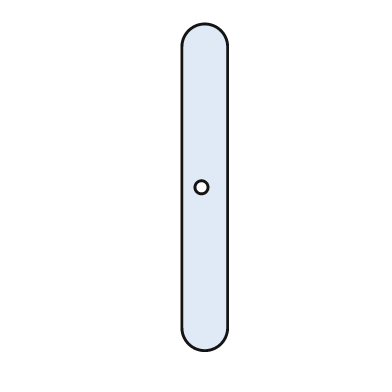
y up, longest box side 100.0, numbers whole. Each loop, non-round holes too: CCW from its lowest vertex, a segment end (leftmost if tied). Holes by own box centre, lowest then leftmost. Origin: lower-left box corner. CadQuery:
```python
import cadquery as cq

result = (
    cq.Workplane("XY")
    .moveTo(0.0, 7.0)
    .threePointArc((7.0, 0.0), (14.0, 7.0))
    .lineTo(14.0, 93.0)
    .threePointArc((7.0, 100.0), (0.0, 93.0))
    .close()
    .moveTo(6.0, 50.0)
    .circle(2.0)
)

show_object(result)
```